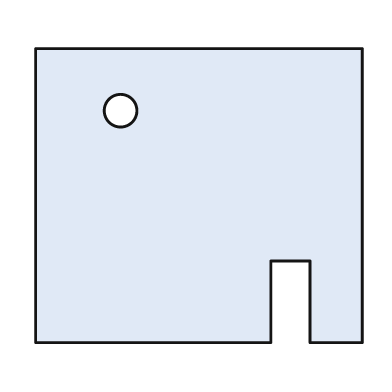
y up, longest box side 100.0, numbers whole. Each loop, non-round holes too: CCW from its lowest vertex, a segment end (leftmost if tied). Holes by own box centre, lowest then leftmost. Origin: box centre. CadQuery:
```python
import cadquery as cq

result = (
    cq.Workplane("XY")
    .moveTo(-50.0, -45.0)
    .lineTo(22.0, -45.0)
    .lineTo(22.0, -20.0)
    .lineTo(34.0, -20.0)
    .lineTo(34.0, -45.0)
    .lineTo(50.0, -45.0)
    .lineTo(50.0, 45.0)
    .lineTo(-50.0, 45.0)
    .close()
    .moveTo(-24.0, 26.0)
    .circle(5.0)
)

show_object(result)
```